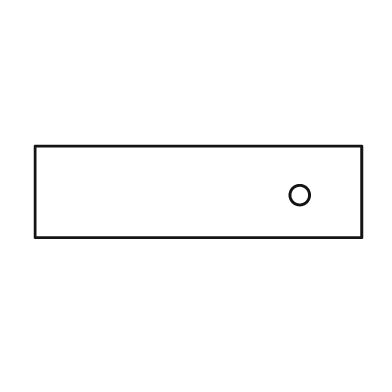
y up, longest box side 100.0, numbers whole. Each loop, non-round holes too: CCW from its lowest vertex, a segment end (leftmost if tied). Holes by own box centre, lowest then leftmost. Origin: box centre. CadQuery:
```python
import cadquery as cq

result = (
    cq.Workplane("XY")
    .moveTo(-50.0, -14.0)
    .lineTo(50.0, -14.0)
    .lineTo(50.0, 14.0)
    .lineTo(-50.0, 14.0)
    .close()
    .moveTo(31.0, -1.0)
    .circle(3.0)
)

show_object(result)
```